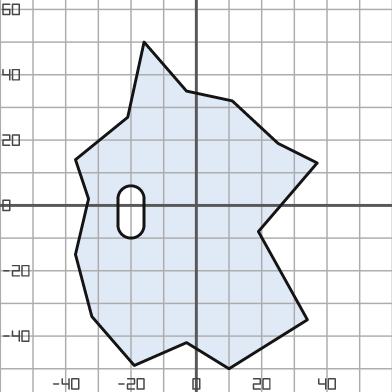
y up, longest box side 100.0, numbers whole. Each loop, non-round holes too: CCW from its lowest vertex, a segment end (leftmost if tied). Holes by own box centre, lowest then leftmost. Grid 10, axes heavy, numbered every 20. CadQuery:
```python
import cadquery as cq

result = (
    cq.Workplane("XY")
    .moveTo(10.0, -50.0)
    .lineTo(34.0, -35.0)
    .lineTo(19.0, -8.0)
    .lineTo(37.0, 13.0)
    .lineTo(25.0, 19.0)
    .lineTo(11.0, 32.0)
    .lineTo(-3.0, 35.0)
    .lineTo(-16.0, 50.0)
    .lineTo(-21.0, 27.0)
    .lineTo(-37.0, 14.0)
    .lineTo(-33.0, 2.0)
    .lineTo(-37.0, -15.0)
    .lineTo(-32.0, -34.0)
    .lineTo(-19.0, -49.0)
    .lineTo(-3.0, -42.0)
    .close()
    .moveTo(-24.0, -6.0)
    .threePointArc((-20.0, -10.0), (-16.0, -6.0))
    .lineTo(-16.0, 2.0)
    .threePointArc((-20.0, 6.0), (-24.0, 2.0))
    .close()
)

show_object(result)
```